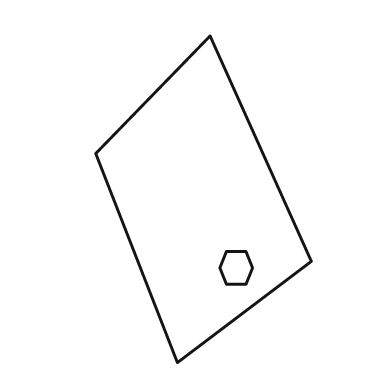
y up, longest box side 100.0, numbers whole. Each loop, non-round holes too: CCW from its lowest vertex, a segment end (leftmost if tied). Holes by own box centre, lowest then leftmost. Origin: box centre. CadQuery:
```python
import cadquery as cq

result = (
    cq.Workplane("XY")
    .moveTo(-8.0, -50.0)
    .lineTo(33.0, -19.0)
    .lineTo(2.0, 50.0)
    .lineTo(-33.0, 14.0)
    .close()
    .moveTo(7.0, -26.0)
    .lineTo(13.0, -26.0)
    .lineTo(15.0, -21.0)
    .lineTo(13.0, -16.0)
    .lineTo(7.0, -16.0)
    .lineTo(5.0, -21.0)
    .close()
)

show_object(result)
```